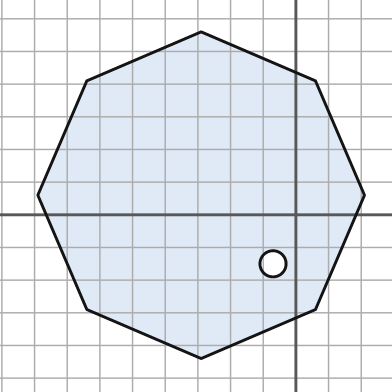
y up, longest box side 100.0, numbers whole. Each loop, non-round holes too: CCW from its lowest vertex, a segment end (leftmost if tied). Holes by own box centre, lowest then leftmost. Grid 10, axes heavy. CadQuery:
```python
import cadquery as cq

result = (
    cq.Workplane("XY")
    .moveTo(-29.0, -44.0)
    .lineTo(6.0, -29.0)
    .lineTo(21.0, 6.0)
    .lineTo(6.0, 41.0)
    .lineTo(-29.0, 56.0)
    .lineTo(-64.0, 41.0)
    .lineTo(-79.0, 6.0)
    .lineTo(-64.0, -29.0)
    .close()
    .moveTo(-7.0, -15.0)
    .circle(4.0)
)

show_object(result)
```